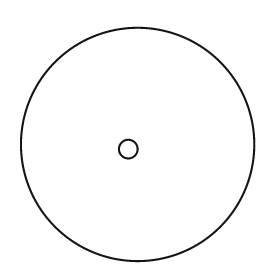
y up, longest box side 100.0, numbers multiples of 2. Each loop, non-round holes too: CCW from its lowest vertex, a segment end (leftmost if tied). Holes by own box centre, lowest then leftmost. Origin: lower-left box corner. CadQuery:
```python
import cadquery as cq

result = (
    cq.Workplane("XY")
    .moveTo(50.0, 50.0)
    .circle(50.0)
    .moveTo(46.0, 48.0)
    .circle(4.0)
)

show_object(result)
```